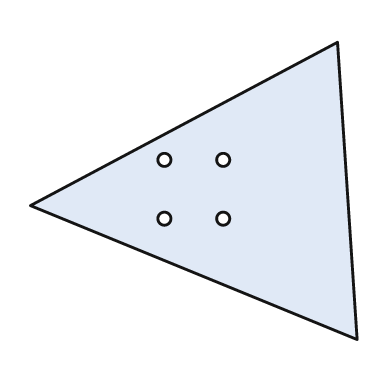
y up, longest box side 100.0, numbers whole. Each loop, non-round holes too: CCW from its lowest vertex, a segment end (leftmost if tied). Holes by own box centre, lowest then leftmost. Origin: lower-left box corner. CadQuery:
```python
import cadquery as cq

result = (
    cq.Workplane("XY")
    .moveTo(100.0, 0.0)
    .lineTo(94.0, 91.0)
    .lineTo(0.0, 41.0)
    .close()
    .moveTo(41.0, 37.0)
    .circle(2.0)
    .moveTo(59.0, 37.0)
    .circle(2.0)
    .moveTo(41.0, 55.0)
    .circle(2.0)
    .moveTo(59.0, 55.0)
    .circle(2.0)
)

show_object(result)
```